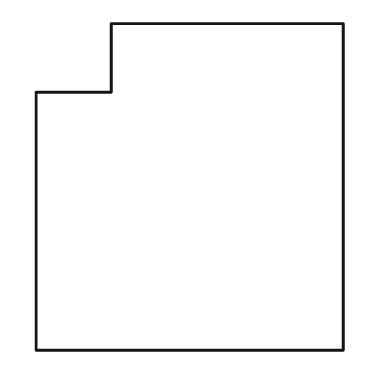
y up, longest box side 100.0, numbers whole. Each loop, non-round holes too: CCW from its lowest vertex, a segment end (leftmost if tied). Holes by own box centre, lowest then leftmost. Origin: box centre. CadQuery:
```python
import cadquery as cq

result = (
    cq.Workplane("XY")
    .moveTo(-47.0, -50.0)
    .lineTo(47.0, -50.0)
    .lineTo(47.0, 50.0)
    .lineTo(-24.0, 50.0)
    .lineTo(-24.0, 29.0)
    .lineTo(-47.0, 29.0)
    .close()
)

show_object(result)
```